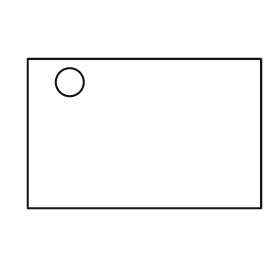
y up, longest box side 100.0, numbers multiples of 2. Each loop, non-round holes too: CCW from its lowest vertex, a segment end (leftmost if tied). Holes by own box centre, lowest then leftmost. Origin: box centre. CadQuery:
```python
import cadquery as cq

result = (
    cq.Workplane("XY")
    .moveTo(-50.0, -32.0)
    .lineTo(50.0, -32.0)
    .lineTo(50.0, 32.0)
    .lineTo(-50.0, 32.0)
    .close()
    .moveTo(-32.0, 22.0)
    .circle(6.0)
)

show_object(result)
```